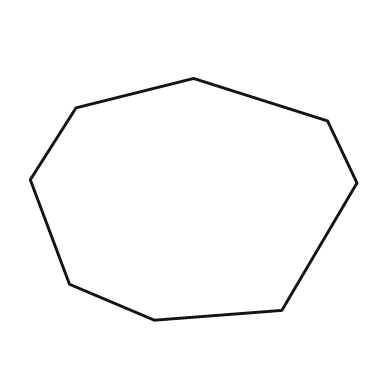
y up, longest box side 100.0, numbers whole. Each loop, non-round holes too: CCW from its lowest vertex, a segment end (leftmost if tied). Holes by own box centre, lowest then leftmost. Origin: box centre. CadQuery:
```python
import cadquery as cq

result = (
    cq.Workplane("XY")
    .moveTo(-12.0, -37.0)
    .lineTo(27.0, -34.0)
    .lineTo(50.0, 5.0)
    .lineTo(41.0, 24.0)
    .lineTo(0.0, 37.0)
    .lineTo(-36.0, 28.0)
    .lineTo(-50.0, 6.0)
    .lineTo(-38.0, -26.0)
    .close()
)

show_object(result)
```